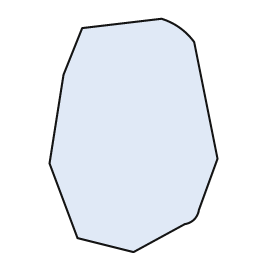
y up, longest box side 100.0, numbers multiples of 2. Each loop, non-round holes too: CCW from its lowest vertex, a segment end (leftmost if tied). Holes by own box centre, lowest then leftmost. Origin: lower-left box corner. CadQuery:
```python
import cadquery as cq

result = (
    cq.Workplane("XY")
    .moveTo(36.0, 0.0)
    .lineTo(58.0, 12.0)
    .threePointArc((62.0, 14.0), (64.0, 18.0))
    .lineTo(72.0, 40.0)
    .lineTo(62.0, 90.0)
    .threePointArc((56.0, 96.0), (48.0, 100.0))
    .lineTo(14.0, 96.0)
    .lineTo(6.0, 76.0)
    .lineTo(0.0, 38.0)
    .lineTo(12.0, 6.0)
    .close()
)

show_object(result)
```